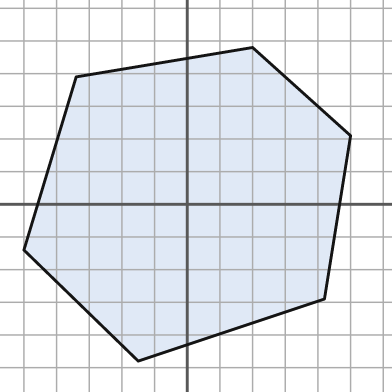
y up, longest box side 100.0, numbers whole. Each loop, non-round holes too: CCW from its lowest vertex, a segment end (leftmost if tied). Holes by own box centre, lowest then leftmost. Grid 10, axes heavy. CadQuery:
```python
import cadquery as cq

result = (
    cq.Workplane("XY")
    .moveTo(-15.0, -48.0)
    .lineTo(42.0, -29.0)
    .lineTo(50.0, 21.0)
    .lineTo(20.0, 48.0)
    .lineTo(-34.0, 39.0)
    .lineTo(-50.0, -14.0)
    .close()
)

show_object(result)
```